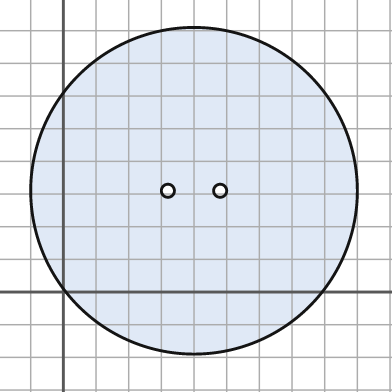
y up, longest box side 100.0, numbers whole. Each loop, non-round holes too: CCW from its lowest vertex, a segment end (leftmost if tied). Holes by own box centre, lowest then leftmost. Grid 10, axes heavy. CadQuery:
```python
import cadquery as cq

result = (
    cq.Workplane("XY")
    .moveTo(40.0, 31.0)
    .circle(50.0)
    .moveTo(32.0, 31.0)
    .circle(2.0)
    .moveTo(48.0, 31.0)
    .circle(2.0)
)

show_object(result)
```